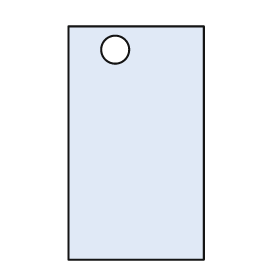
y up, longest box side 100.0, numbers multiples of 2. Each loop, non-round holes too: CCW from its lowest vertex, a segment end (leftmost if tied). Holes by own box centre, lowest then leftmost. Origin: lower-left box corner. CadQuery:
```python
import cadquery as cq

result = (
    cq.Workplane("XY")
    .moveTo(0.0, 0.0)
    .lineTo(58.0, 0.0)
    .lineTo(58.0, 100.0)
    .lineTo(0.0, 100.0)
    .close()
    .moveTo(20.0, 90.0)
    .circle(6.0)
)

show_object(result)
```